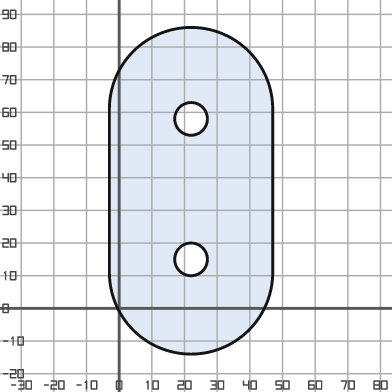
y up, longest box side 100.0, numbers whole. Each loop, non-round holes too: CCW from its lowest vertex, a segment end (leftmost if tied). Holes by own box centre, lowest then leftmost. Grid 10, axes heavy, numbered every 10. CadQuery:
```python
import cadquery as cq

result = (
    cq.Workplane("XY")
    .moveTo(-3.0, 11.0)
    .threePointArc((22.0, -14.0), (47.0, 11.0))
    .lineTo(47.0, 61.0)
    .threePointArc((22.0, 86.0), (-3.0, 61.0))
    .close()
    .moveTo(22.0, 15.0)
    .circle(5.0)
    .moveTo(22.0, 58.0)
    .circle(5.0)
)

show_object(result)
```